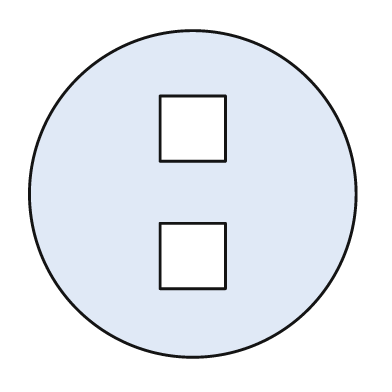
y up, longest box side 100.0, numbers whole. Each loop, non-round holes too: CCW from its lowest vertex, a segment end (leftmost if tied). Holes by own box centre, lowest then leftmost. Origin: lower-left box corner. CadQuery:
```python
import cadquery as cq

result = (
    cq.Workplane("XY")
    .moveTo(50.0, 50.0)
    .circle(50.0)
    .moveTo(40.0, 21.0)
    .lineTo(60.0, 21.0)
    .lineTo(60.0, 41.0)
    .lineTo(40.0, 41.0)
    .close()
    .moveTo(40.0, 60.0)
    .lineTo(60.0, 60.0)
    .lineTo(60.0, 80.0)
    .lineTo(40.0, 80.0)
    .close()
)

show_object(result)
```